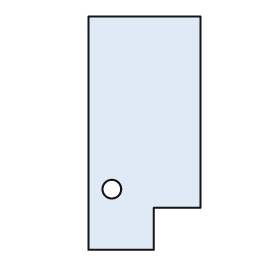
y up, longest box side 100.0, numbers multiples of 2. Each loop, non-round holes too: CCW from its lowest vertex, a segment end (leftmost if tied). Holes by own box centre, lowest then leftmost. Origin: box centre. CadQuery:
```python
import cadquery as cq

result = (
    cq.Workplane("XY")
    .moveTo(-24.0, -50.0)
    .lineTo(4.0, -50.0)
    .lineTo(4.0, -32.0)
    .lineTo(24.0, -32.0)
    .lineTo(24.0, 50.0)
    .lineTo(-24.0, 50.0)
    .close()
    .moveTo(-14.0, -24.0)
    .circle(4.0)
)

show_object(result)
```